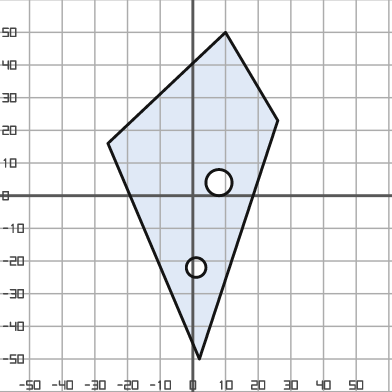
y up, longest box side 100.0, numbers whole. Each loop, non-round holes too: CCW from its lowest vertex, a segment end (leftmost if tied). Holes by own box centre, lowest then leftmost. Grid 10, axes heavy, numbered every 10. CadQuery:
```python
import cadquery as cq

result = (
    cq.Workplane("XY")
    .moveTo(2.0, -50.0)
    .lineTo(26.0, 23.0)
    .lineTo(10.0, 50.0)
    .lineTo(-26.0, 16.0)
    .close()
    .moveTo(1.0, -22.0)
    .circle(3.0)
    .moveTo(8.0, 4.0)
    .circle(4.0)
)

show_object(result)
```